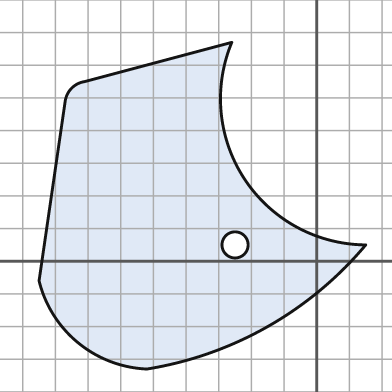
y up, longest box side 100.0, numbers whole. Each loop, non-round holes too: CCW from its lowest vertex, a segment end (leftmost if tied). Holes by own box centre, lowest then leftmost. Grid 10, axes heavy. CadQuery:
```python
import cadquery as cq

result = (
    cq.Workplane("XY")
    .moveTo(-52.0, -33.0)
    .threePointArc((-15.0, -20.0), (15.0, 5.0))
    .threePointArc((-22.0, 25.0), (-26.0, 67.0))
    .lineTo(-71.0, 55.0)
    .threePointArc((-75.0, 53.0), (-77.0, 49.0))
    .lineTo(-85.0, -6.0)
    .threePointArc((-73.0, -25.0), (-52.0, -33.0))
    .close()
    .moveTo(-25.0, 5.0)
    .circle(4.0)
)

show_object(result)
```